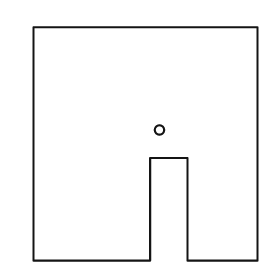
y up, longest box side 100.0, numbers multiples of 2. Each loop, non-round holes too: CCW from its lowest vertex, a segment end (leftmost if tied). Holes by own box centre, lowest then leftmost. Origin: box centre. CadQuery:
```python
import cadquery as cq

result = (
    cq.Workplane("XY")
    .moveTo(-48.0, -50.0)
    .lineTo(2.0, -50.0)
    .lineTo(2.0, -6.0)
    .lineTo(18.0, -6.0)
    .lineTo(18.0, -50.0)
    .lineTo(48.0, -50.0)
    .lineTo(48.0, 50.0)
    .lineTo(-48.0, 50.0)
    .close()
    .moveTo(6.0, 6.0)
    .circle(2.0)
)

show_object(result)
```